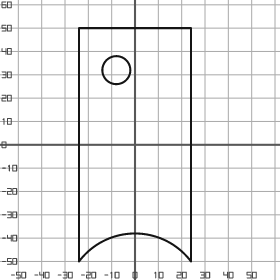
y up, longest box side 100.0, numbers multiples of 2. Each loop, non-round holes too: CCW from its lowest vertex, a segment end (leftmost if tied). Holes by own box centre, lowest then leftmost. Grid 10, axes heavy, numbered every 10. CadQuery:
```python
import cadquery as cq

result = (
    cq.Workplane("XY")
    .moveTo(-24.0, -50.0)
    .threePointArc((0.0, -38.0), (24.0, -50.0))
    .lineTo(24.0, 50.0)
    .lineTo(-24.0, 50.0)
    .close()
    .moveTo(-8.0, 32.0)
    .circle(6.0)
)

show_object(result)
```